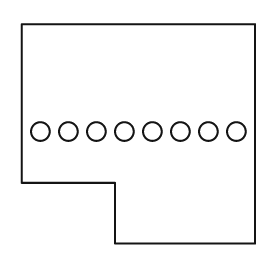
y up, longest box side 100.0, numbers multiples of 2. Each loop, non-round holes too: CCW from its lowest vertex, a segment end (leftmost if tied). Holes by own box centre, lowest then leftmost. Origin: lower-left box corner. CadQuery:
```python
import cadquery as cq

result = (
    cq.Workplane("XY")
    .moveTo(40.0, 0.0)
    .lineTo(100.0, 0.0)
    .lineTo(100.0, 94.0)
    .lineTo(0.0, 94.0)
    .lineTo(0.0, 26.0)
    .lineTo(40.0, 26.0)
    .close()
    .moveTo(8.0, 48.0)
    .circle(4.0)
    .moveTo(20.0, 48.0)
    .circle(4.0)
    .moveTo(32.0, 48.0)
    .circle(4.0)
    .moveTo(44.0, 48.0)
    .circle(4.0)
    .moveTo(56.0, 48.0)
    .circle(4.0)
    .moveTo(68.0, 48.0)
    .circle(4.0)
    .moveTo(80.0, 48.0)
    .circle(4.0)
    .moveTo(92.0, 48.0)
    .circle(4.0)
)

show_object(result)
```